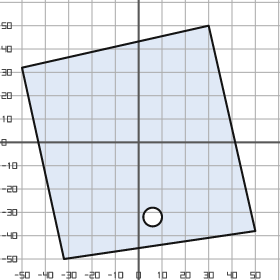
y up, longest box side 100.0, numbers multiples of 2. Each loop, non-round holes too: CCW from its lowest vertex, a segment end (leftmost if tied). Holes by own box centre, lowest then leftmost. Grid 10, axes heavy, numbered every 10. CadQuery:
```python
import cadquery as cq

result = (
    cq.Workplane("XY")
    .moveTo(-32.0, -50.0)
    .lineTo(50.0, -38.0)
    .lineTo(30.0, 50.0)
    .lineTo(-50.0, 32.0)
    .close()
    .moveTo(6.0, -32.0)
    .circle(4.0)
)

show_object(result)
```